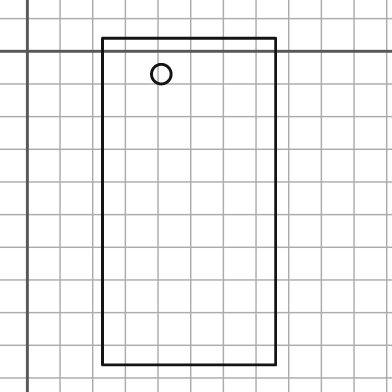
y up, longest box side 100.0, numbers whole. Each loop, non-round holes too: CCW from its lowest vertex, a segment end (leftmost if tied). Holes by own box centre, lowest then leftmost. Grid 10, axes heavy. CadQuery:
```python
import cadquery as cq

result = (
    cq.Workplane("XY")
    .moveTo(23.0, -96.0)
    .lineTo(76.0, -96.0)
    .lineTo(76.0, 4.0)
    .lineTo(23.0, 4.0)
    .close()
    .moveTo(41.0, -7.0)
    .circle(3.0)
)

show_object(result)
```